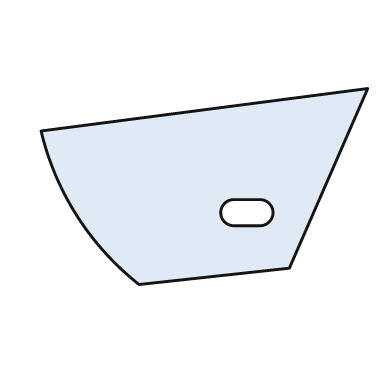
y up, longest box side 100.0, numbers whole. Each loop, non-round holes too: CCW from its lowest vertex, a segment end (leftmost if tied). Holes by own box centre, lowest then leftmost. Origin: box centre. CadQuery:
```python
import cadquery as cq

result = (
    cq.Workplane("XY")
    .moveTo(-20.0, -30.0)
    .lineTo(26.0, -25.0)
    .lineTo(50.0, 30.0)
    .lineTo(-50.0, 17.0)
    .threePointArc((-39.0, -9.0), (-20.0, -30.0))
    .close()
    .moveTo(9.0, -12.0)
    .lineTo(17.0, -12.0)
    .threePointArc((21.0, -8.0), (17.0, -4.0))
    .lineTo(9.0, -4.0)
    .threePointArc((5.0, -8.0), (9.0, -12.0))
    .close()
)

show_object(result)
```